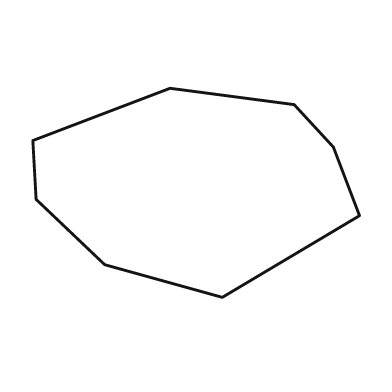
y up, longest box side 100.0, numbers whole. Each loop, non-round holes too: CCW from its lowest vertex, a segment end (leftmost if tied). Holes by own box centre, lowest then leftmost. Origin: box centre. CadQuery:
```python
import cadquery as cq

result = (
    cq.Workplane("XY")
    .moveTo(8.0, -32.0)
    .lineTo(50.0, -7.0)
    .lineTo(42.0, 14.0)
    .lineTo(30.0, 27.0)
    .lineTo(-8.0, 32.0)
    .lineTo(-50.0, 16.0)
    .lineTo(-49.0, -2.0)
    .lineTo(-28.0, -22.0)
    .close()
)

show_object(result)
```